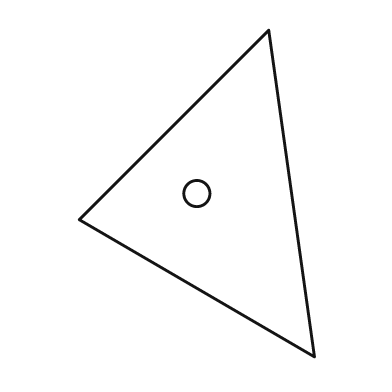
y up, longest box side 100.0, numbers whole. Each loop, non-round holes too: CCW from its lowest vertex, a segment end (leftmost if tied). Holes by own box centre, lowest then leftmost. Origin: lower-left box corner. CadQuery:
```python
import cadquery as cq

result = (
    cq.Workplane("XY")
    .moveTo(72.0, 0.0)
    .lineTo(58.0, 100.0)
    .lineTo(0.0, 42.0)
    .close()
    .moveTo(36.0, 50.0)
    .circle(4.0)
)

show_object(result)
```